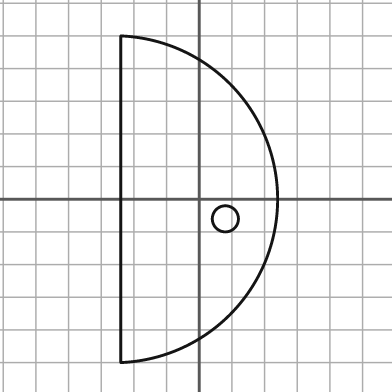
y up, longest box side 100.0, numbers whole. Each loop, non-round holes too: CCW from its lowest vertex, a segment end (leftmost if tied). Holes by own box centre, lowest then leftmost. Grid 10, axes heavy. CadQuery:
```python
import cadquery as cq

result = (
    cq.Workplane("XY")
    .moveTo(-24.0, -50.0)
    .threePointArc((24.0, 0.0), (-24.0, 50.0))
    .close()
    .moveTo(8.0, -6.0)
    .circle(4.0)
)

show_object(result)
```